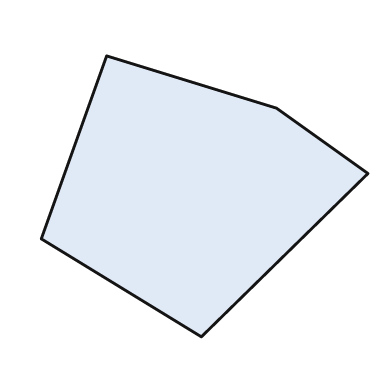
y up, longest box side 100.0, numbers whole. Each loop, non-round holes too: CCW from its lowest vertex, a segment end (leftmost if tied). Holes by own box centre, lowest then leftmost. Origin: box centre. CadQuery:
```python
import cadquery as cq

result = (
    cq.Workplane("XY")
    .moveTo(-1.0, -43.0)
    .lineTo(50.0, 7.0)
    .lineTo(22.0, 27.0)
    .lineTo(-30.0, 43.0)
    .lineTo(-50.0, -13.0)
    .close()
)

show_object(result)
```